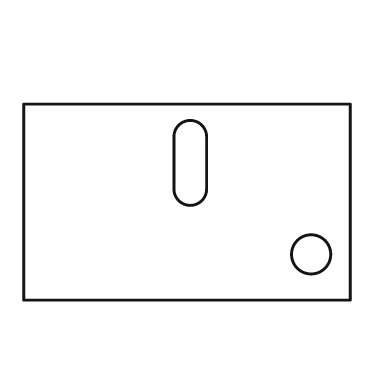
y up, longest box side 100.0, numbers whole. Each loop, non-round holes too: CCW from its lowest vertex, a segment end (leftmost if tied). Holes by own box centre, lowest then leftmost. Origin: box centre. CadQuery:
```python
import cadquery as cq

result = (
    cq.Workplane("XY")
    .moveTo(-50.0, -30.0)
    .lineTo(50.0, -30.0)
    .lineTo(50.0, 30.0)
    .lineTo(-50.0, 30.0)
    .close()
    .moveTo(38.0, -16.0)
    .circle(6.0)
    .moveTo(-4.0, 4.0)
    .threePointArc((1.0, -1.0), (6.0, 4.0))
    .lineTo(6.0, 20.0)
    .threePointArc((1.0, 25.0), (-4.0, 20.0))
    .close()
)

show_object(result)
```